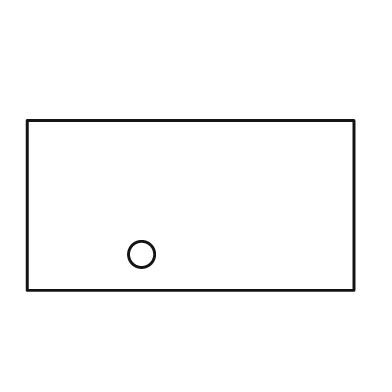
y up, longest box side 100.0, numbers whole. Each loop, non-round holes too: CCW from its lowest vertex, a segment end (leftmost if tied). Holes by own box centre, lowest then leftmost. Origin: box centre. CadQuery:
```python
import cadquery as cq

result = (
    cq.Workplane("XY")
    .moveTo(-50.0, -26.0)
    .lineTo(50.0, -26.0)
    .lineTo(50.0, 26.0)
    .lineTo(-50.0, 26.0)
    .close()
    .moveTo(-15.0, -15.0)
    .circle(4.0)
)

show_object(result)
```